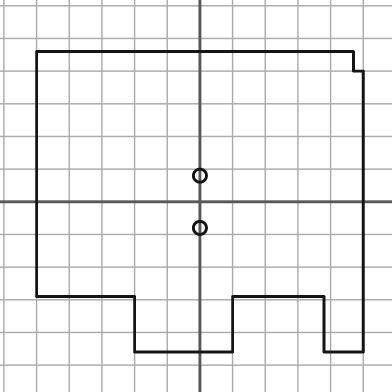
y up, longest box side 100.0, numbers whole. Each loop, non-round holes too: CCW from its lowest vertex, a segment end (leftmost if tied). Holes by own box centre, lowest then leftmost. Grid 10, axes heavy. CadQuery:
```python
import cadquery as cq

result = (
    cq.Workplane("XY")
    .moveTo(-20.0, -46.0)
    .lineTo(10.0, -46.0)
    .lineTo(10.0, -29.0)
    .lineTo(38.0, -29.0)
    .lineTo(38.0, -46.0)
    .lineTo(50.0, -46.0)
    .lineTo(50.0, 40.0)
    .lineTo(47.0, 40.0)
    .lineTo(47.0, 46.0)
    .lineTo(-50.0, 46.0)
    .lineTo(-50.0, -29.0)
    .lineTo(-20.0, -29.0)
    .close()
    .moveTo(0.0, -8.0)
    .circle(2.0)
    .moveTo(0.0, 8.0)
    .circle(2.0)
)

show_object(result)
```